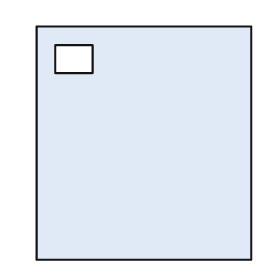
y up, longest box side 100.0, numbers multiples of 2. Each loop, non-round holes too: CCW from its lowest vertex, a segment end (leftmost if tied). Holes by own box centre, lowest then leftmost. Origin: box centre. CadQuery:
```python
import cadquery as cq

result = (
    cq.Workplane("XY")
    .moveTo(-46.0, -50.0)
    .lineTo(46.0, -50.0)
    .lineTo(46.0, 50.0)
    .lineTo(-46.0, 50.0)
    .close()
    .moveTo(-38.0, 30.0)
    .lineTo(-22.0, 30.0)
    .lineTo(-22.0, 42.0)
    .lineTo(-38.0, 42.0)
    .close()
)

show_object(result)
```